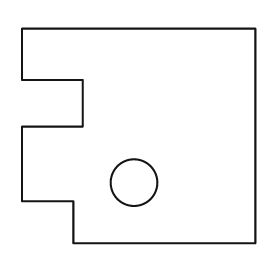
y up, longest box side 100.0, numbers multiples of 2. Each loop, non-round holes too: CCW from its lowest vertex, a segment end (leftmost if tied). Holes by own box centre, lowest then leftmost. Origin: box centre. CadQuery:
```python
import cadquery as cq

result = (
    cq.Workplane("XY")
    .moveTo(-28.0, -46.0)
    .lineTo(50.0, -46.0)
    .lineTo(50.0, 46.0)
    .lineTo(-50.0, 46.0)
    .lineTo(-50.0, 24.0)
    .lineTo(-24.0, 24.0)
    .lineTo(-24.0, 4.0)
    .lineTo(-50.0, 4.0)
    .lineTo(-50.0, -28.0)
    .lineTo(-28.0, -28.0)
    .close()
    .moveTo(-2.0, -20.0)
    .circle(10.0)
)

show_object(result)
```